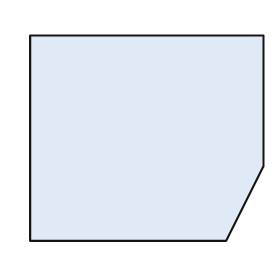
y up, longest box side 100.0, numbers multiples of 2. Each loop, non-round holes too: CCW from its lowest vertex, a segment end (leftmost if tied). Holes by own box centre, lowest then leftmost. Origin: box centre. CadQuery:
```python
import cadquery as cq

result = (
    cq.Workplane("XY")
    .moveTo(-50.0, -44.0)
    .lineTo(34.0, -44.0)
    .lineTo(50.0, -12.0)
    .lineTo(50.0, 44.0)
    .lineTo(-50.0, 44.0)
    .close()
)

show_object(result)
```